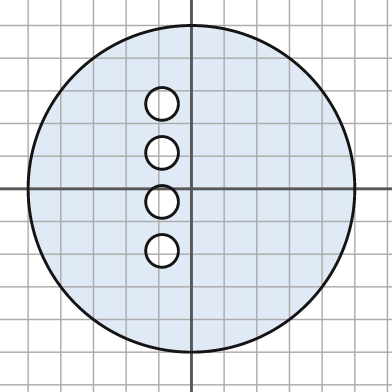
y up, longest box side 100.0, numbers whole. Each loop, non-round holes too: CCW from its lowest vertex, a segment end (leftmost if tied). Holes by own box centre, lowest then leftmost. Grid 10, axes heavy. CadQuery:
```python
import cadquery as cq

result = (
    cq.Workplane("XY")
    .moveTo(0.0, 0.0)
    .circle(50.0)
    .moveTo(-9.0, -19.0)
    .circle(5.0)
    .moveTo(-9.0, -4.0)
    .circle(5.0)
    .moveTo(-9.0, 11.0)
    .circle(5.0)
    .moveTo(-9.0, 26.0)
    .circle(5.0)
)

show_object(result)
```